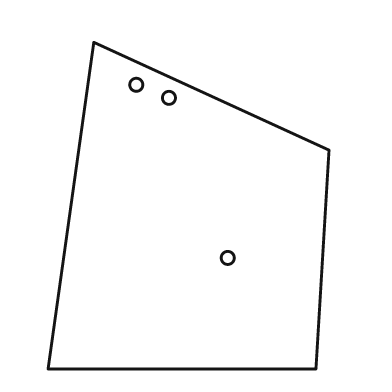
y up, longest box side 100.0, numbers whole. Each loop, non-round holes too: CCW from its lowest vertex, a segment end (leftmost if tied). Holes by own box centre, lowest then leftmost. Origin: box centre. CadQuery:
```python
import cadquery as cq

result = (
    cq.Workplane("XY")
    .moveTo(-43.0, -50.0)
    .lineTo(39.0, -50.0)
    .lineTo(43.0, 17.0)
    .lineTo(-29.0, 50.0)
    .close()
    .moveTo(12.0, -16.0)
    .circle(2.0)
    .moveTo(-6.0, 33.0)
    .circle(2.0)
    .moveTo(-16.0, 37.0)
    .circle(2.0)
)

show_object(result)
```